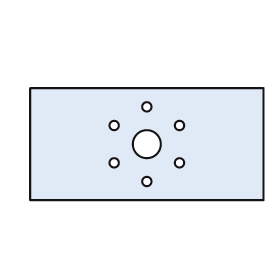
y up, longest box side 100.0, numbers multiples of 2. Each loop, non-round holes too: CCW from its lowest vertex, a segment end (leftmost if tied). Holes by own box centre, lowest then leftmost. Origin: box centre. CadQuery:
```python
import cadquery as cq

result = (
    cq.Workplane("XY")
    .moveTo(-50.0, -24.0)
    .lineTo(50.0, -24.0)
    .lineTo(50.0, 24.0)
    .lineTo(-50.0, 24.0)
    .close()
    .moveTo(0.0, -16.0)
    .circle(2.0)
    .moveTo(-14.0, -8.0)
    .circle(2.0)
    .moveTo(14.0, -8.0)
    .circle(2.0)
    .moveTo(0.0, 0.0)
    .circle(6.0)
    .moveTo(-14.0, 8.0)
    .circle(2.0)
    .moveTo(14.0, 8.0)
    .circle(2.0)
    .moveTo(0.0, 16.0)
    .circle(2.0)
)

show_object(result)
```